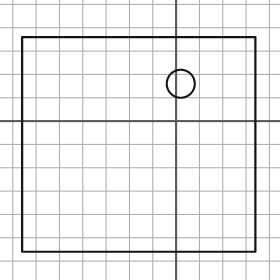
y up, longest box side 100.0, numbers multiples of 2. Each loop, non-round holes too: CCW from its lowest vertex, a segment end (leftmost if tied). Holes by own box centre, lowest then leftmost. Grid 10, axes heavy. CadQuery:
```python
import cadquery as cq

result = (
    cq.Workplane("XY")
    .moveTo(-66.0, -56.0)
    .lineTo(34.0, -56.0)
    .lineTo(34.0, 36.0)
    .lineTo(-66.0, 36.0)
    .close()
    .moveTo(2.0, 16.0)
    .circle(6.0)
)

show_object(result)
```